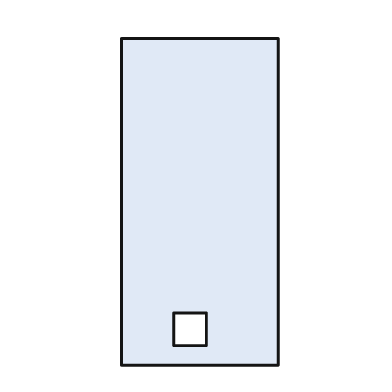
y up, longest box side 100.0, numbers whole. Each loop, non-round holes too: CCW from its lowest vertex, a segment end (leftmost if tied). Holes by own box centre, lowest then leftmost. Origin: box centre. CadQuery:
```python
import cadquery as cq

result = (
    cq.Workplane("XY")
    .moveTo(-24.0, -50.0)
    .lineTo(24.0, -50.0)
    .lineTo(24.0, 50.0)
    .lineTo(-24.0, 50.0)
    .close()
    .moveTo(-8.0, -44.0)
    .lineTo(2.0, -44.0)
    .lineTo(2.0, -34.0)
    .lineTo(-8.0, -34.0)
    .close()
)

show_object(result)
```